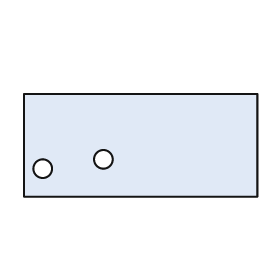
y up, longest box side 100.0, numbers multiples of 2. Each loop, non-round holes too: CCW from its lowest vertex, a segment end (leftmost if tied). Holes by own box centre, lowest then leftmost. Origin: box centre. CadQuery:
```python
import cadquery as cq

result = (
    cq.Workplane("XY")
    .moveTo(-50.0, -22.0)
    .lineTo(50.0, -22.0)
    .lineTo(50.0, 22.0)
    .lineTo(-50.0, 22.0)
    .close()
    .moveTo(-42.0, -10.0)
    .circle(4.0)
    .moveTo(-16.0, -6.0)
    .circle(4.0)
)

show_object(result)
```